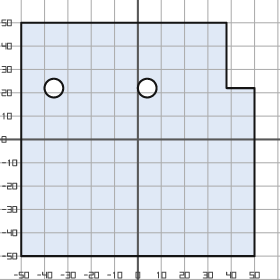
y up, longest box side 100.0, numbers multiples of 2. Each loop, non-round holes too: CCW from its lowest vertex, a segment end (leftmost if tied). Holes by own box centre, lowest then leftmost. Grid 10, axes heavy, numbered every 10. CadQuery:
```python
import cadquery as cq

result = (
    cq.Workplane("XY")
    .moveTo(-50.0, -50.0)
    .lineTo(50.0, -50.0)
    .lineTo(50.0, 22.0)
    .lineTo(38.0, 22.0)
    .lineTo(38.0, 50.0)
    .lineTo(-50.0, 50.0)
    .close()
    .moveTo(-36.0, 22.0)
    .circle(4.0)
    .moveTo(4.0, 22.0)
    .circle(4.0)
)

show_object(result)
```